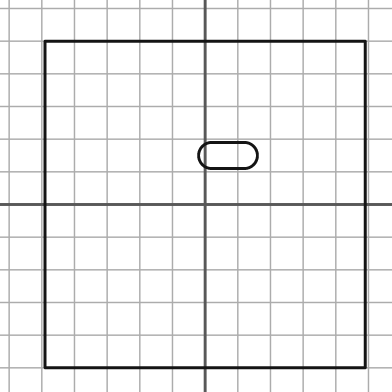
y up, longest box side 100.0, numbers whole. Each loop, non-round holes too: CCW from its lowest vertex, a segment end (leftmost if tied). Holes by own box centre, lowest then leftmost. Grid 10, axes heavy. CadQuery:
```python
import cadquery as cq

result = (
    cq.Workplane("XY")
    .moveTo(-49.0, -50.0)
    .lineTo(49.0, -50.0)
    .lineTo(49.0, 50.0)
    .lineTo(-49.0, 50.0)
    .close()
    .moveTo(2.0, 11.0)
    .lineTo(12.0, 11.0)
    .threePointArc((16.0, 15.0), (12.0, 19.0))
    .lineTo(2.0, 19.0)
    .threePointArc((-2.0, 15.0), (2.0, 11.0))
    .close()
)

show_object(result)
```